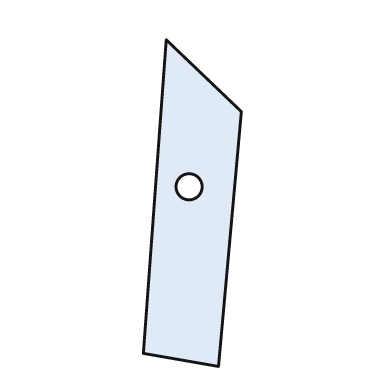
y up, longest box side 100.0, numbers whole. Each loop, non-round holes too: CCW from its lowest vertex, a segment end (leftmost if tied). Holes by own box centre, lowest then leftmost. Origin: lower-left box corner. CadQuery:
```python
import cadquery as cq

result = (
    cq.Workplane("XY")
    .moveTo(23.0, 0.0)
    .lineTo(30.0, 78.0)
    .lineTo(7.0, 100.0)
    .lineTo(0.0, 4.0)
    .close()
    .moveTo(14.0, 55.0)
    .circle(4.0)
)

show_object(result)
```